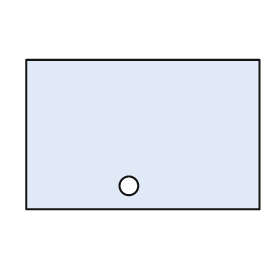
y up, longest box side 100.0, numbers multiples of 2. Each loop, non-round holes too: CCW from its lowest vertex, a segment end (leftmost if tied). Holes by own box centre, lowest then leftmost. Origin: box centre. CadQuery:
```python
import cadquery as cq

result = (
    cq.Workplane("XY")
    .moveTo(-50.0, -32.0)
    .lineTo(50.0, -32.0)
    .lineTo(50.0, 32.0)
    .lineTo(-50.0, 32.0)
    .close()
    .moveTo(-6.0, -22.0)
    .circle(4.0)
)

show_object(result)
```